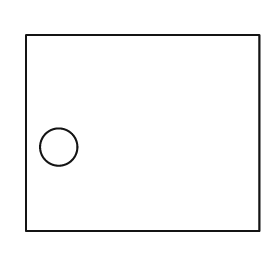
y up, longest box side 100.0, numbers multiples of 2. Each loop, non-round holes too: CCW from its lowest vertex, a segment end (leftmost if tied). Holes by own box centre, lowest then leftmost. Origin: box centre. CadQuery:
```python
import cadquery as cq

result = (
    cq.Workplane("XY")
    .moveTo(-50.0, -42.0)
    .lineTo(50.0, -42.0)
    .lineTo(50.0, 42.0)
    .lineTo(-50.0, 42.0)
    .close()
    .moveTo(-36.0, -6.0)
    .circle(8.0)
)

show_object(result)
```